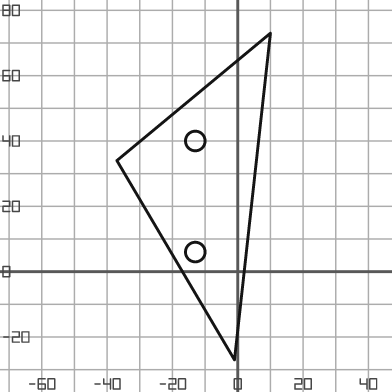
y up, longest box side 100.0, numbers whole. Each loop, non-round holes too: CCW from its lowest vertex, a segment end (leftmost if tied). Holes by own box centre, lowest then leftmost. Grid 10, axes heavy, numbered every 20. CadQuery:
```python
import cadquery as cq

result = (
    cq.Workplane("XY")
    .moveTo(-1.0, -27.0)
    .lineTo(10.0, 73.0)
    .lineTo(-37.0, 34.0)
    .close()
    .moveTo(-13.0, 6.0)
    .circle(3.0)
    .moveTo(-13.0, 40.0)
    .circle(3.0)
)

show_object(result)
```